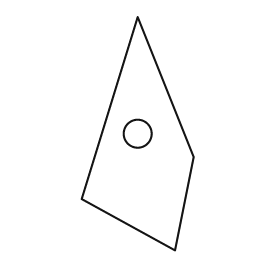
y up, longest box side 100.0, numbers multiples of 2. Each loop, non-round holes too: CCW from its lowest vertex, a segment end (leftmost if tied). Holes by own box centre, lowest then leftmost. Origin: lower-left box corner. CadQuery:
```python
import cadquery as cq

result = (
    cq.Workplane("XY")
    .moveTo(40.0, 0.0)
    .lineTo(48.0, 40.0)
    .lineTo(24.0, 100.0)
    .lineTo(0.0, 22.0)
    .close()
    .moveTo(24.0, 50.0)
    .circle(6.0)
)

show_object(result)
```